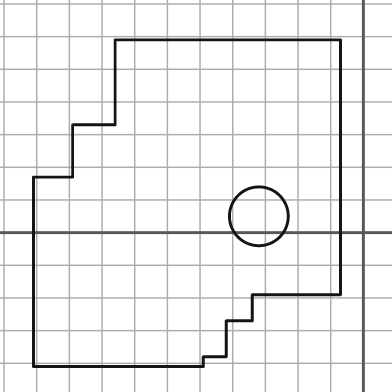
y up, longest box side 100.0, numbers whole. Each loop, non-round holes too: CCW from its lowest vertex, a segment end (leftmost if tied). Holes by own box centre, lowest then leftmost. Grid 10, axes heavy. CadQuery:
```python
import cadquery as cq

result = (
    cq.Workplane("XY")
    .moveTo(-101.0, -41.0)
    .lineTo(-49.0, -41.0)
    .lineTo(-49.0, -38.0)
    .lineTo(-42.0, -38.0)
    .lineTo(-42.0, -27.0)
    .lineTo(-34.0, -27.0)
    .lineTo(-34.0, -19.0)
    .lineTo(-7.0, -19.0)
    .lineTo(-7.0, 59.0)
    .lineTo(-76.0, 59.0)
    .lineTo(-76.0, 33.0)
    .lineTo(-89.0, 33.0)
    .lineTo(-89.0, 17.0)
    .lineTo(-101.0, 17.0)
    .close()
    .moveTo(-32.0, 5.0)
    .circle(9.0)
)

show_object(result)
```